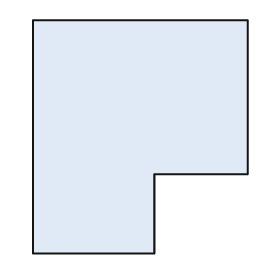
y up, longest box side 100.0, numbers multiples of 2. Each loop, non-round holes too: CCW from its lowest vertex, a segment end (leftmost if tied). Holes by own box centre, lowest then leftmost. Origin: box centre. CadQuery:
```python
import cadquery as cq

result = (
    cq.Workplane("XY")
    .moveTo(-46.0, -50.0)
    .lineTo(6.0, -50.0)
    .lineTo(6.0, -16.0)
    .lineTo(46.0, -16.0)
    .lineTo(46.0, 50.0)
    .lineTo(-46.0, 50.0)
    .close()
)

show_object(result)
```